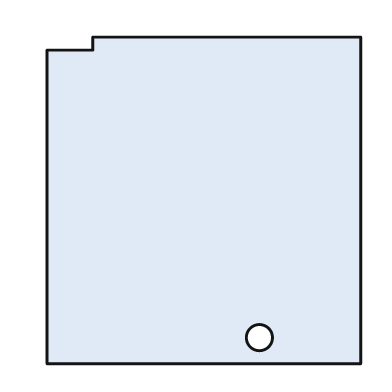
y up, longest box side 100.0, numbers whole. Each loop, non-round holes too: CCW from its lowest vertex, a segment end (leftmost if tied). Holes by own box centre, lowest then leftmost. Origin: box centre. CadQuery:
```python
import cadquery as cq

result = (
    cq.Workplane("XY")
    .moveTo(-48.0, -50.0)
    .lineTo(48.0, -50.0)
    .lineTo(48.0, 50.0)
    .lineTo(-34.0, 50.0)
    .lineTo(-34.0, 46.0)
    .lineTo(-48.0, 46.0)
    .close()
    .moveTo(17.0, -42.0)
    .circle(4.0)
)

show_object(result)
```